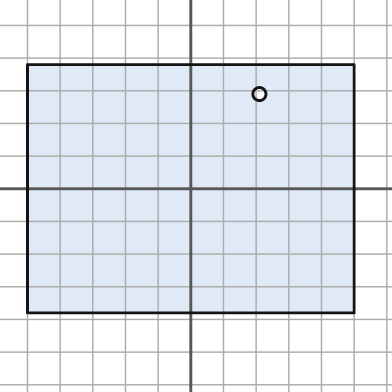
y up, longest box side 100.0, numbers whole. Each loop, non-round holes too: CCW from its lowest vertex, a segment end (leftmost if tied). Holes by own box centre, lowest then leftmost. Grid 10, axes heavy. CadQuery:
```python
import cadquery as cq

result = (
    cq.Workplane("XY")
    .moveTo(-50.0, -38.0)
    .lineTo(50.0, -38.0)
    .lineTo(50.0, 38.0)
    .lineTo(-50.0, 38.0)
    .close()
    .moveTo(21.0, 29.0)
    .circle(2.0)
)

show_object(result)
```